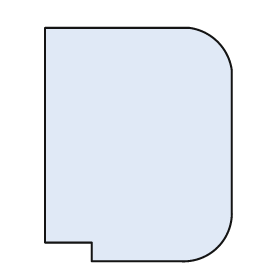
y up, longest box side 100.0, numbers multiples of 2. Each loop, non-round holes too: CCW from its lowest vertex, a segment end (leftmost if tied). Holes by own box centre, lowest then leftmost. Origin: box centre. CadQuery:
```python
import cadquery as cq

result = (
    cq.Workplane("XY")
    .moveTo(-20.0, -50.0)
    .lineTo(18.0, -50.0)
    .threePointArc((34.0, -44.0), (40.0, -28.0))
    .lineTo(40.0, 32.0)
    .threePointArc((34.0, 44.0), (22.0, 50.0))
    .lineTo(-40.0, 50.0)
    .lineTo(-40.0, -42.0)
    .lineTo(-20.0, -42.0)
    .close()
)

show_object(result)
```